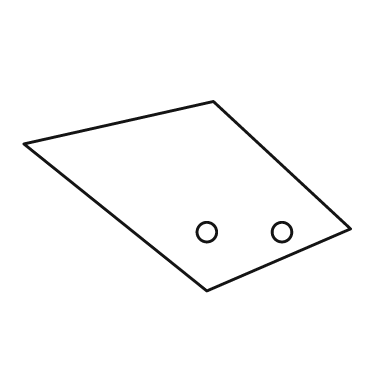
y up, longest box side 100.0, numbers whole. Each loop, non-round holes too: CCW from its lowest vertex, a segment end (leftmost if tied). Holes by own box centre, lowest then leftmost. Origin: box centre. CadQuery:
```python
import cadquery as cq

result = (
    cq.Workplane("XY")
    .moveTo(6.0, -29.0)
    .lineTo(50.0, -10.0)
    .lineTo(8.0, 29.0)
    .lineTo(-50.0, 16.0)
    .close()
    .moveTo(6.0, -11.0)
    .circle(3.0)
    .moveTo(29.0, -11.0)
    .circle(3.0)
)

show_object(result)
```